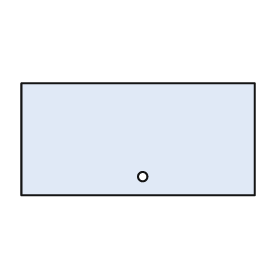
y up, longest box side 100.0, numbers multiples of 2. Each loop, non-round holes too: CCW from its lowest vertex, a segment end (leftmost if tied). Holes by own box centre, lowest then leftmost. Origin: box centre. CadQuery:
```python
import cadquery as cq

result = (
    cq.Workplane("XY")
    .moveTo(-50.0, -24.0)
    .lineTo(50.0, -24.0)
    .lineTo(50.0, 24.0)
    .lineTo(-50.0, 24.0)
    .close()
    .moveTo(2.0, -16.0)
    .circle(2.0)
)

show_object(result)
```